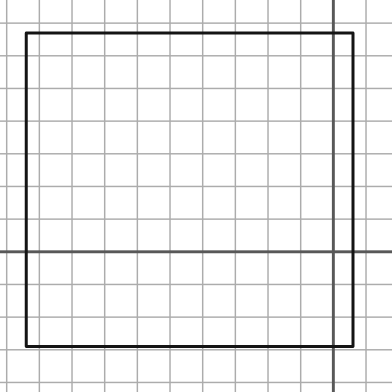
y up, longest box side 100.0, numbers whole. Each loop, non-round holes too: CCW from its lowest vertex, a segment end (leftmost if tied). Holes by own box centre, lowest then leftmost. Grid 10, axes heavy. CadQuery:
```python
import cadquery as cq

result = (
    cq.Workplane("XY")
    .moveTo(-94.0, -29.0)
    .lineTo(6.0, -29.0)
    .lineTo(6.0, 67.0)
    .lineTo(-94.0, 67.0)
    .close()
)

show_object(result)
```